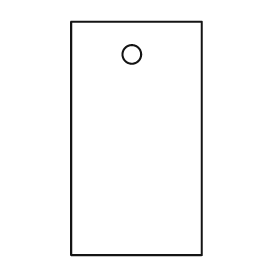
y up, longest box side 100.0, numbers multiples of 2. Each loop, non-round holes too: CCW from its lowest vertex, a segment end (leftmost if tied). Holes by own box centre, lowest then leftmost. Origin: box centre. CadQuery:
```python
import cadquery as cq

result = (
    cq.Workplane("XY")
    .moveTo(-28.0, -50.0)
    .lineTo(28.0, -50.0)
    .lineTo(28.0, 50.0)
    .lineTo(-28.0, 50.0)
    .close()
    .moveTo(-2.0, 36.0)
    .circle(4.0)
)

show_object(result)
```